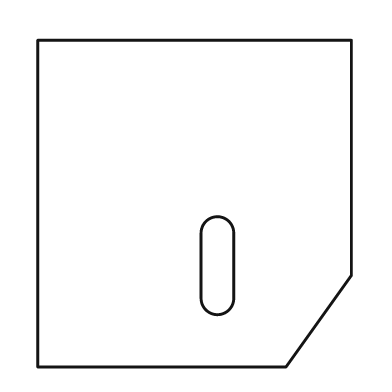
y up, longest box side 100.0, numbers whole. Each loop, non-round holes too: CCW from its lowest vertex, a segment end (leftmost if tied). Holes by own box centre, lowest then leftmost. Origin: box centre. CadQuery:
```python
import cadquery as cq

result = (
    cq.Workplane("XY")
    .moveTo(-48.0, -50.0)
    .lineTo(28.0, -50.0)
    .lineTo(48.0, -22.0)
    .lineTo(48.0, 50.0)
    .lineTo(-48.0, 50.0)
    .close()
    .moveTo(2.0, -29.0)
    .threePointArc((7.0, -34.0), (12.0, -29.0))
    .lineTo(12.0, -9.0)
    .threePointArc((7.0, -4.0), (2.0, -9.0))
    .close()
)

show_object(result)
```